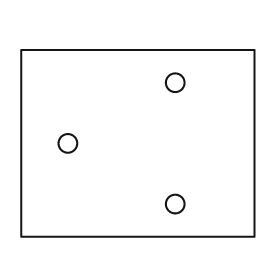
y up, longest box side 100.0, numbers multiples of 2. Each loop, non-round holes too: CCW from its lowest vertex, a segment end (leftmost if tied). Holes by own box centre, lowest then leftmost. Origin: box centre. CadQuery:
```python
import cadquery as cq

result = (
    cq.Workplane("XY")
    .moveTo(-50.0, -40.0)
    .lineTo(50.0, -40.0)
    .lineTo(50.0, 40.0)
    .lineTo(-50.0, 40.0)
    .close()
    .moveTo(16.0, -26.0)
    .circle(4.0)
    .moveTo(-30.0, 0.0)
    .circle(4.0)
    .moveTo(16.0, 26.0)
    .circle(4.0)
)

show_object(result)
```